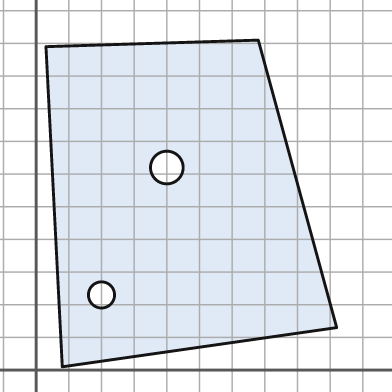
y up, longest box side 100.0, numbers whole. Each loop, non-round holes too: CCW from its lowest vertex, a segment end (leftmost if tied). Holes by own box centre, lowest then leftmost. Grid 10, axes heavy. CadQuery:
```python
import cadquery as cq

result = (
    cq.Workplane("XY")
    .moveTo(8.0, 1.0)
    .lineTo(92.0, 13.0)
    .lineTo(68.0, 101.0)
    .lineTo(3.0, 99.0)
    .close()
    .moveTo(20.0, 23.0)
    .circle(4.0)
    .moveTo(40.0, 62.0)
    .circle(5.0)
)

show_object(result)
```